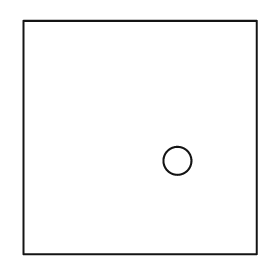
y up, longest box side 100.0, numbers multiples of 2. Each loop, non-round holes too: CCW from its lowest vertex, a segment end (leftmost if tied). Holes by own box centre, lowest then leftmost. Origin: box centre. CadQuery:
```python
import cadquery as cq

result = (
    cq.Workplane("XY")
    .moveTo(-50.0, -50.0)
    .lineTo(50.0, -50.0)
    .lineTo(50.0, 50.0)
    .lineTo(-50.0, 50.0)
    .close()
    .moveTo(16.0, -10.0)
    .circle(6.0)
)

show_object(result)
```